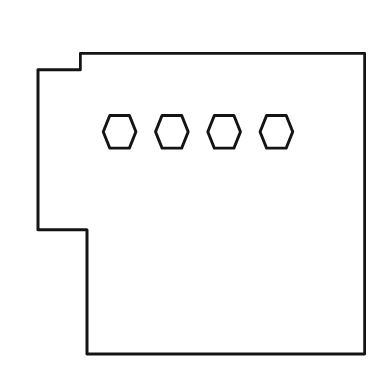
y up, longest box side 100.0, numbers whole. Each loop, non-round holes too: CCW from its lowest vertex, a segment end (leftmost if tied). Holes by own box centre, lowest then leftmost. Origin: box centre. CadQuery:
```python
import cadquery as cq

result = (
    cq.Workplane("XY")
    .moveTo(-35.0, -46.0)
    .lineTo(50.0, -46.0)
    .lineTo(50.0, 46.0)
    .lineTo(-37.0, 46.0)
    .lineTo(-37.0, 41.0)
    .lineTo(-50.0, 41.0)
    .lineTo(-50.0, -8.0)
    .lineTo(-35.0, -8.0)
    .close()
    .moveTo(-28.0, 17.0)
    .lineTo(-22.0, 17.0)
    .lineTo(-20.0, 22.0)
    .lineTo(-22.0, 27.0)
    .lineTo(-28.0, 27.0)
    .lineTo(-30.0, 22.0)
    .close()
    .moveTo(-12.0, 17.0)
    .lineTo(-6.0, 17.0)
    .lineTo(-4.0, 22.0)
    .lineTo(-6.0, 27.0)
    .lineTo(-12.0, 27.0)
    .lineTo(-14.0, 22.0)
    .close()
    .moveTo(4.0, 17.0)
    .lineTo(10.0, 17.0)
    .lineTo(12.0, 22.0)
    .lineTo(10.0, 27.0)
    .lineTo(4.0, 27.0)
    .lineTo(2.0, 22.0)
    .close()
    .moveTo(20.0, 17.0)
    .lineTo(26.0, 17.0)
    .lineTo(28.0, 22.0)
    .lineTo(26.0, 27.0)
    .lineTo(20.0, 27.0)
    .lineTo(18.0, 22.0)
    .close()
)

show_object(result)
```